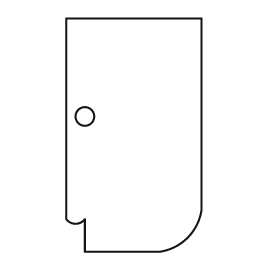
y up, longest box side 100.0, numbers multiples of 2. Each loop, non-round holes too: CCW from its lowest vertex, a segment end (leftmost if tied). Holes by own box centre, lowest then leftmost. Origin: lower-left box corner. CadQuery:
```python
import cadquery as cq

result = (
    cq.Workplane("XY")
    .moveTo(8.0, 0.0)
    .lineTo(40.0, 0.0)
    .threePointArc((52.0, 6.0), (58.0, 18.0))
    .lineTo(58.0, 100.0)
    .lineTo(0.0, 100.0)
    .lineTo(0.0, 14.0)
    .threePointArc((4.0, 12.0), (8.0, 14.0))
    .close()
    .moveTo(8.0, 58.0)
    .circle(4.0)
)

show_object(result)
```